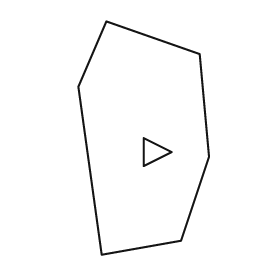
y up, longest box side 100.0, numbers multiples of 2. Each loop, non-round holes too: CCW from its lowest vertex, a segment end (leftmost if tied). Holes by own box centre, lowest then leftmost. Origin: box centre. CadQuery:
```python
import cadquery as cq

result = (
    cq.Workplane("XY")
    .moveTo(-18.0, -50.0)
    .lineTo(16.0, -44.0)
    .lineTo(28.0, -8.0)
    .lineTo(24.0, 36.0)
    .lineTo(-16.0, 50.0)
    .lineTo(-28.0, 22.0)
    .close()
    .moveTo(0.0, -12.0)
    .lineTo(12.0, -6.0)
    .lineTo(0.0, 0.0)
    .close()
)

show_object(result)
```